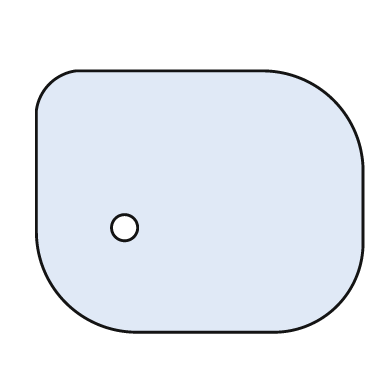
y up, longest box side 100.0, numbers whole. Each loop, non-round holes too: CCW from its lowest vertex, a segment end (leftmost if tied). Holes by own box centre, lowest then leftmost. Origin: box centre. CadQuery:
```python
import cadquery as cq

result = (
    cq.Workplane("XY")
    .moveTo(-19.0, -40.0)
    .lineTo(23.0, -40.0)
    .threePointArc((42.0, -32.0), (50.0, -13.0))
    .lineTo(50.0, 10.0)
    .threePointArc((41.0, 31.0), (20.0, 40.0))
    .lineTo(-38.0, 40.0)
    .threePointArc((-46.0, 36.0), (-50.0, 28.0))
    .lineTo(-50.0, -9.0)
    .threePointArc((-41.0, -31.0), (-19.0, -40.0))
    .close()
    .moveTo(-23.0, -8.0)
    .circle(4.0)
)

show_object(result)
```